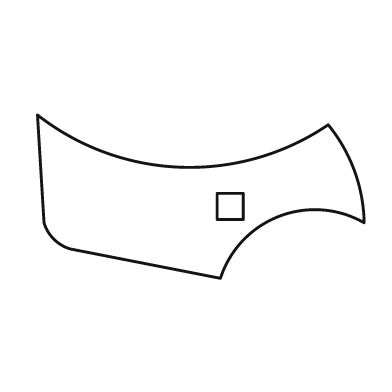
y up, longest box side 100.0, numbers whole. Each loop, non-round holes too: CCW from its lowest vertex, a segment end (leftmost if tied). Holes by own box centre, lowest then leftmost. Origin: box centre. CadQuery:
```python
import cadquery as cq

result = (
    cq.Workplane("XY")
    .moveTo(6.0, -25.0)
    .threePointArc((24.0, -6.0), (50.0, -8.0))
    .threePointArc((47.0, 8.0), (39.0, 22.0))
    .threePointArc((-6.0, 9.0), (-50.0, 25.0))
    .lineTo(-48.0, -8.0)
    .threePointArc((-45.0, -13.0), (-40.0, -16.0))
    .close()
    .moveTo(5.0, -7.0)
    .lineTo(13.0, -7.0)
    .lineTo(13.0, 1.0)
    .lineTo(5.0, 1.0)
    .close()
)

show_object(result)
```